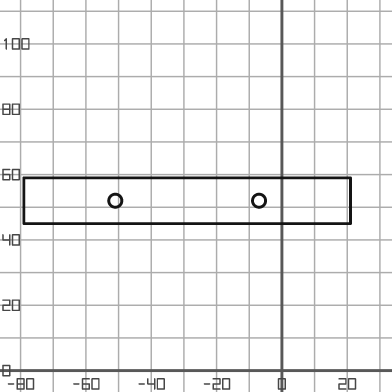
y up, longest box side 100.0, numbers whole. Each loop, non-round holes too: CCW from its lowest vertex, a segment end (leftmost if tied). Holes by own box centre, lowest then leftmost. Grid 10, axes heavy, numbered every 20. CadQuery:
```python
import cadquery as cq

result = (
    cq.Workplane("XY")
    .moveTo(-79.0, 45.0)
    .lineTo(21.0, 45.0)
    .lineTo(21.0, 59.0)
    .lineTo(-79.0, 59.0)
    .close()
    .moveTo(-51.0, 52.0)
    .circle(2.0)
    .moveTo(-7.0, 52.0)
    .circle(2.0)
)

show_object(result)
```